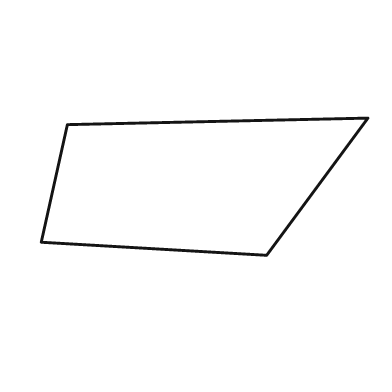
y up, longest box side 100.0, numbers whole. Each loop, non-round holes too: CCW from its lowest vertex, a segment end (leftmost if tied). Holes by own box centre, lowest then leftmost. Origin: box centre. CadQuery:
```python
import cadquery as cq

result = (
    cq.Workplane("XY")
    .moveTo(19.0, -21.0)
    .lineTo(50.0, 21.0)
    .lineTo(-42.0, 19.0)
    .lineTo(-50.0, -17.0)
    .close()
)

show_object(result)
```